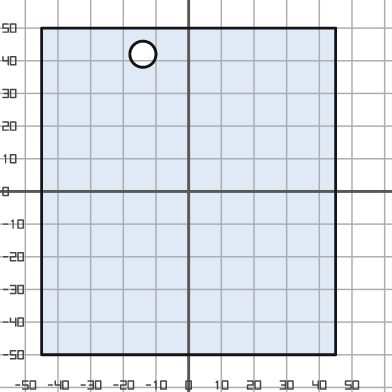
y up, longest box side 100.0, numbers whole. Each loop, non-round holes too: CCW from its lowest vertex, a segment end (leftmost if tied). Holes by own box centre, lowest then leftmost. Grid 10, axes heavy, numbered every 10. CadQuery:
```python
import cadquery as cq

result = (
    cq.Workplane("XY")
    .moveTo(-45.0, -50.0)
    .lineTo(45.0, -50.0)
    .lineTo(45.0, 50.0)
    .lineTo(-45.0, 50.0)
    .close()
    .moveTo(-14.0, 42.0)
    .circle(4.0)
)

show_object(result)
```